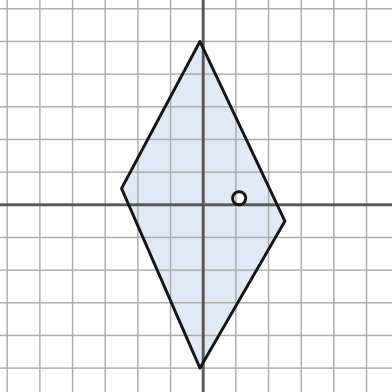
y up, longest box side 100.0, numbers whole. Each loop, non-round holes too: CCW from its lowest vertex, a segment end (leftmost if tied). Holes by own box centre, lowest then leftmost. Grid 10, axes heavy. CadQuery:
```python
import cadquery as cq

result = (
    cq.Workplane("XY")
    .moveTo(-1.0, -50.0)
    .lineTo(25.0, -5.0)
    .lineTo(-1.0, 50.0)
    .lineTo(-25.0, 5.0)
    .close()
    .moveTo(11.0, 2.0)
    .circle(2.0)
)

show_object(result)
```